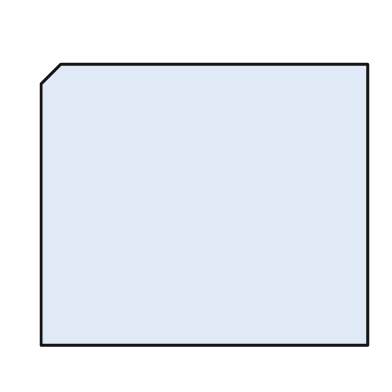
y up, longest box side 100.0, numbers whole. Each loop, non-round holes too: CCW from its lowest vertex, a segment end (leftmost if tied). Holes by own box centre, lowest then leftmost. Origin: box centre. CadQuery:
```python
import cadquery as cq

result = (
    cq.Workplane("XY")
    .moveTo(-50.0, -43.0)
    .lineTo(50.0, -43.0)
    .lineTo(50.0, 43.0)
    .lineTo(-44.0, 43.0)
    .lineTo(-50.0, 37.0)
    .close()
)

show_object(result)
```